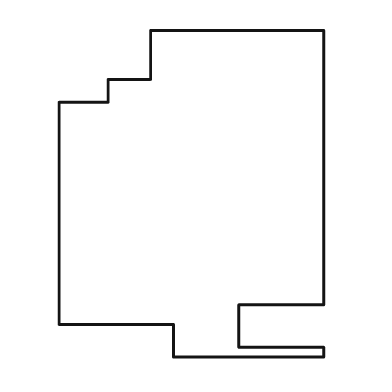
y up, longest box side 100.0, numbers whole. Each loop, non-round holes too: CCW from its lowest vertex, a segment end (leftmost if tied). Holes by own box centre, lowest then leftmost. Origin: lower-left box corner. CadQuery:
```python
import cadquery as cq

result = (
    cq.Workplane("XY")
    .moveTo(35.0, 0.0)
    .lineTo(81.0, 0.0)
    .lineTo(81.0, 3.0)
    .lineTo(55.0, 3.0)
    .lineTo(55.0, 16.0)
    .lineTo(81.0, 16.0)
    .lineTo(81.0, 100.0)
    .lineTo(28.0, 100.0)
    .lineTo(28.0, 85.0)
    .lineTo(15.0, 85.0)
    .lineTo(15.0, 78.0)
    .lineTo(0.0, 78.0)
    .lineTo(0.0, 10.0)
    .lineTo(35.0, 10.0)
    .close()
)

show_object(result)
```